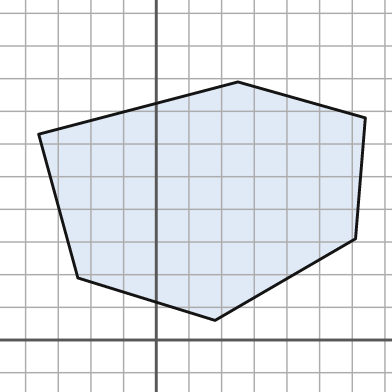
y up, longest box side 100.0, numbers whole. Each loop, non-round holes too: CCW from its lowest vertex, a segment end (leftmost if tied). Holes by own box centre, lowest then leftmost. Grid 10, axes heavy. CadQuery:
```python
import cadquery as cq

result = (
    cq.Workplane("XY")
    .moveTo(18.0, 6.0)
    .lineTo(61.0, 31.0)
    .lineTo(64.0, 68.0)
    .lineTo(25.0, 79.0)
    .lineTo(-36.0, 63.0)
    .lineTo(-24.0, 19.0)
    .close()
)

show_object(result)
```